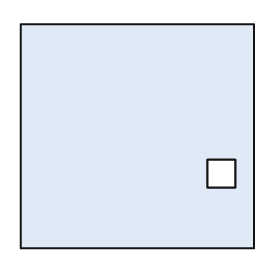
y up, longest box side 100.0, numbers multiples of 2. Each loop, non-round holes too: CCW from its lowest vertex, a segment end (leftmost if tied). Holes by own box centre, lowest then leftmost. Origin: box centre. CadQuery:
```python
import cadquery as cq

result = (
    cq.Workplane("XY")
    .moveTo(-50.0, -48.0)
    .lineTo(50.0, -48.0)
    .lineTo(50.0, 48.0)
    .lineTo(-50.0, 48.0)
    .close()
    .moveTo(30.0, -22.0)
    .lineTo(42.0, -22.0)
    .lineTo(42.0, -10.0)
    .lineTo(30.0, -10.0)
    .close()
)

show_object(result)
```